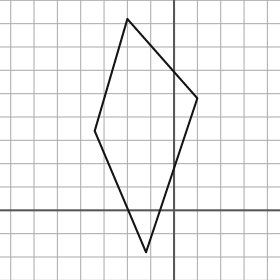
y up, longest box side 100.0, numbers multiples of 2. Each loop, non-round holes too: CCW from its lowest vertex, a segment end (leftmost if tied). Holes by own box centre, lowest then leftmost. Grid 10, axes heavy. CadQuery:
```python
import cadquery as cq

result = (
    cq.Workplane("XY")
    .moveTo(-12.0, -18.0)
    .lineTo(10.0, 48.0)
    .lineTo(-20.0, 82.0)
    .lineTo(-34.0, 34.0)
    .close()
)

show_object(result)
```